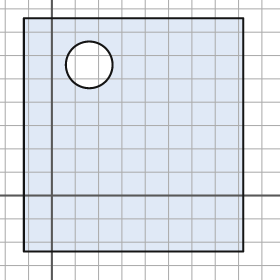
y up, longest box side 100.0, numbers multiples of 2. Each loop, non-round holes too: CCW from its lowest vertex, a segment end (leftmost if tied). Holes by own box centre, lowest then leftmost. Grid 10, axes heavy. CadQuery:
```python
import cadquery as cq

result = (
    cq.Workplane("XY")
    .moveTo(-12.0, -24.0)
    .lineTo(82.0, -24.0)
    .lineTo(82.0, 76.0)
    .lineTo(-12.0, 76.0)
    .close()
    .moveTo(16.0, 56.0)
    .circle(10.0)
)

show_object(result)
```